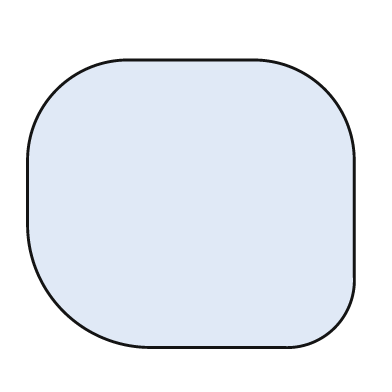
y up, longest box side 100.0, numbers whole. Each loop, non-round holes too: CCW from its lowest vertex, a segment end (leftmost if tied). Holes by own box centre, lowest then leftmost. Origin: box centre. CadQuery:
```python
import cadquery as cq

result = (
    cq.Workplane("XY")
    .moveTo(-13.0, -44.0)
    .lineTo(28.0, -44.0)
    .threePointArc((44.0, -38.0), (50.0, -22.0))
    .lineTo(50.0, 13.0)
    .threePointArc((41.0, 35.0), (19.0, 44.0))
    .lineTo(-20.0, 44.0)
    .threePointArc((-41.0, 35.0), (-50.0, 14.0))
    .lineTo(-50.0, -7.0)
    .threePointArc((-39.0, -33.0), (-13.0, -44.0))
    .close()
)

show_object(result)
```